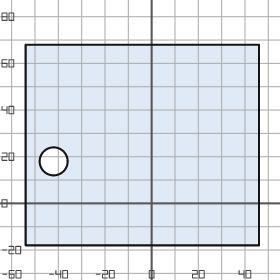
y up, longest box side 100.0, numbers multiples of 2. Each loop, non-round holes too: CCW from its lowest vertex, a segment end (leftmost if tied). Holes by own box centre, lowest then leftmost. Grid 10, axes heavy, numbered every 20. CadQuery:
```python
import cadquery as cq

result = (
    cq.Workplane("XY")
    .moveTo(-54.0, -18.0)
    .lineTo(46.0, -18.0)
    .lineTo(46.0, 68.0)
    .lineTo(-54.0, 68.0)
    .close()
    .moveTo(-42.0, 18.0)
    .circle(6.0)
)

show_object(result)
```